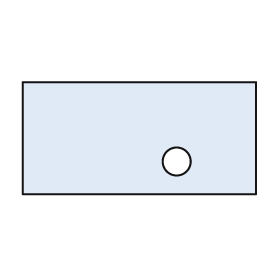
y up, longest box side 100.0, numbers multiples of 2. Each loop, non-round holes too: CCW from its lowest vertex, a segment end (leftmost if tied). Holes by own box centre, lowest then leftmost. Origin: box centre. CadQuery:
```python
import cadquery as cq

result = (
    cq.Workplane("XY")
    .moveTo(-50.0, -24.0)
    .lineTo(50.0, -24.0)
    .lineTo(50.0, 24.0)
    .lineTo(-50.0, 24.0)
    .close()
    .moveTo(16.0, -10.0)
    .circle(6.0)
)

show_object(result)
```